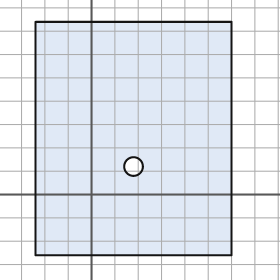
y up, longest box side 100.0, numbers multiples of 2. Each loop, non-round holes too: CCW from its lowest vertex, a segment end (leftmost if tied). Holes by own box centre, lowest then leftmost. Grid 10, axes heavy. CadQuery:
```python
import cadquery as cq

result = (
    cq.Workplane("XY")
    .moveTo(-24.0, -26.0)
    .lineTo(60.0, -26.0)
    .lineTo(60.0, 74.0)
    .lineTo(-24.0, 74.0)
    .close()
    .moveTo(18.0, 12.0)
    .circle(4.0)
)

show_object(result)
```